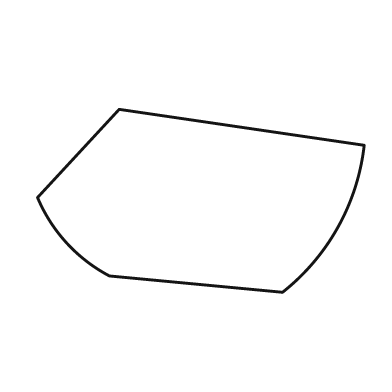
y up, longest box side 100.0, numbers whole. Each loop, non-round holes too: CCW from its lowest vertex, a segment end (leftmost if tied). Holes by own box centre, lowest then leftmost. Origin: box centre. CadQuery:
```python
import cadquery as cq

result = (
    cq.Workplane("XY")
    .moveTo(25.0, -28.0)
    .threePointArc((42.0, -8.0), (50.0, 17.0))
    .lineTo(-25.0, 28.0)
    .lineTo(-50.0, 1.0)
    .threePointArc((-41.0, -13.0), (-28.0, -23.0))
    .close()
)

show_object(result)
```